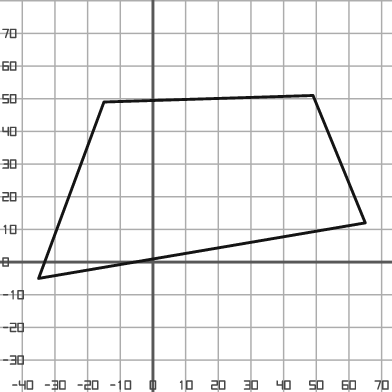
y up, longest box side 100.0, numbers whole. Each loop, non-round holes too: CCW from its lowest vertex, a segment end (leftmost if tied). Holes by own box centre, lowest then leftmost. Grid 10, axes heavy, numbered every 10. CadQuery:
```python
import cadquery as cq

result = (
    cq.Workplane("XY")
    .moveTo(-35.0, -5.0)
    .lineTo(65.0, 12.0)
    .lineTo(49.0, 51.0)
    .lineTo(-15.0, 49.0)
    .close()
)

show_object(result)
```